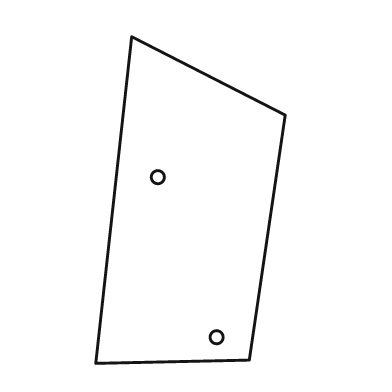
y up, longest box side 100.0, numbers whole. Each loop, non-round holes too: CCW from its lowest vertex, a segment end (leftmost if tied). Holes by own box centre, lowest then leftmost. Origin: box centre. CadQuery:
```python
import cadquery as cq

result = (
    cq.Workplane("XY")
    .moveTo(-29.0, -50.0)
    .lineTo(18.0, -49.0)
    .lineTo(29.0, 26.0)
    .lineTo(-18.0, 50.0)
    .close()
    .moveTo(8.0, -42.0)
    .circle(2.0)
    .moveTo(-10.0, 7.0)
    .circle(2.0)
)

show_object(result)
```